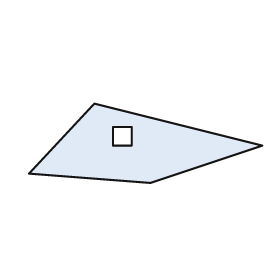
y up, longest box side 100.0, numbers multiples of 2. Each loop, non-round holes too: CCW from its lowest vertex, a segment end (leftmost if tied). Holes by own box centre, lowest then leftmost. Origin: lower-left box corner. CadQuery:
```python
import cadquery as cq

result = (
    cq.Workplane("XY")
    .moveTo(52.0, 0.0)
    .lineTo(100.0, 16.0)
    .lineTo(28.0, 34.0)
    .lineTo(0.0, 4.0)
    .close()
    .moveTo(36.0, 16.0)
    .lineTo(44.0, 16.0)
    .lineTo(44.0, 24.0)
    .lineTo(36.0, 24.0)
    .close()
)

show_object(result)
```